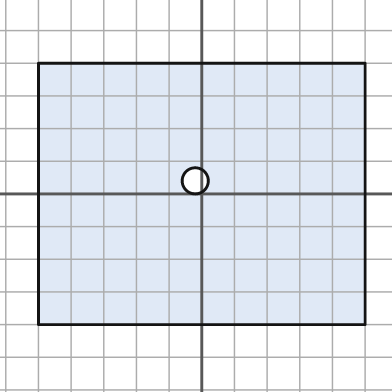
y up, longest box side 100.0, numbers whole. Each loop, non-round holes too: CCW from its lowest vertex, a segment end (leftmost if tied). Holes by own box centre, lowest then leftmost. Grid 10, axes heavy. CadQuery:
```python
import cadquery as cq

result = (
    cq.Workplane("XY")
    .moveTo(-50.0, -40.0)
    .lineTo(50.0, -40.0)
    .lineTo(50.0, 40.0)
    .lineTo(-50.0, 40.0)
    .close()
    .moveTo(-2.0, 4.0)
    .circle(4.0)
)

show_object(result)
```